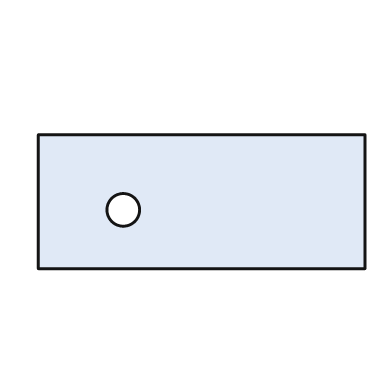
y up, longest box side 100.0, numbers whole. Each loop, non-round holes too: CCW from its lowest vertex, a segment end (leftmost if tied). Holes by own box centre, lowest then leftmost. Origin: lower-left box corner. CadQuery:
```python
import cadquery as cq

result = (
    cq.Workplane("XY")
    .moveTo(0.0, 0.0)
    .lineTo(100.0, 0.0)
    .lineTo(100.0, 41.0)
    .lineTo(0.0, 41.0)
    .close()
    .moveTo(26.0, 18.0)
    .circle(5.0)
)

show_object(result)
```